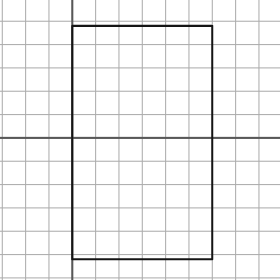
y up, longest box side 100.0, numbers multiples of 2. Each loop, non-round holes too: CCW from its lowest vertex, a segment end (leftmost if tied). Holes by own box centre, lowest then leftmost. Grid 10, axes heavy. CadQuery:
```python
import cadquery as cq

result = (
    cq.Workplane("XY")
    .moveTo(0.0, -52.0)
    .lineTo(60.0, -52.0)
    .lineTo(60.0, 48.0)
    .lineTo(0.0, 48.0)
    .close()
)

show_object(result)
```